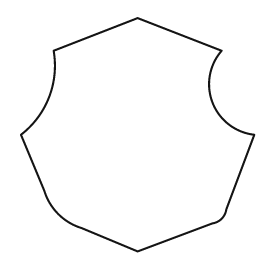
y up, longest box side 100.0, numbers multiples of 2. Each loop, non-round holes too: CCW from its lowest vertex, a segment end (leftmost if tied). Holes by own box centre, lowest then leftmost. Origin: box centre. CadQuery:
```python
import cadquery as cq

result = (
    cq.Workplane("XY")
    .moveTo(0.0, -50.0)
    .lineTo(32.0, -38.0)
    .threePointArc((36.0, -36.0), (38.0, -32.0))
    .lineTo(50.0, 0.0)
    .threePointArc((32.0, 14.0), (36.0, 36.0))
    .lineTo(0.0, 50.0)
    .lineTo(-36.0, 36.0)
    .threePointArc((-38.0, 16.0), (-50.0, 0.0))
    .lineTo(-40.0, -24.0)
    .threePointArc((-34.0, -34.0), (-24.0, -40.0))
    .close()
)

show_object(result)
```